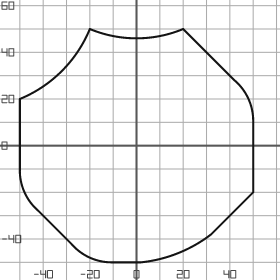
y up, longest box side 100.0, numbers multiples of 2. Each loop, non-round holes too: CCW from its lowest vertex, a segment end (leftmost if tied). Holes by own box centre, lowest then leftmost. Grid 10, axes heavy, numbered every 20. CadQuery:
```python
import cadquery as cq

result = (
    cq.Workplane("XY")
    .moveTo(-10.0, -50.0)
    .lineTo(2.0, -50.0)
    .threePointArc((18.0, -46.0), (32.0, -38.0))
    .lineTo(50.0, -20.0)
    .lineTo(50.0, 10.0)
    .threePointArc((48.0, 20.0), (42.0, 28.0))
    .lineTo(20.0, 50.0)
    .threePointArc((0.0, 46.0), (-20.0, 50.0))
    .threePointArc((-32.0, 32.0), (-50.0, 20.0))
    .lineTo(-50.0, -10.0)
    .threePointArc((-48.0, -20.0), (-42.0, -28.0))
    .lineTo(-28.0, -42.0)
    .threePointArc((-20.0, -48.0), (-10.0, -50.0))
    .close()
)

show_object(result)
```